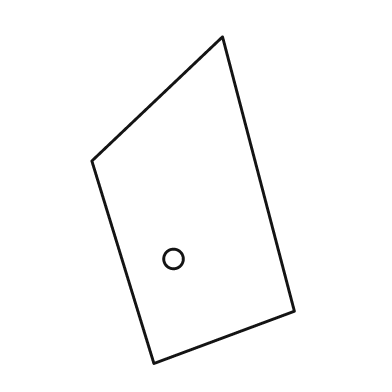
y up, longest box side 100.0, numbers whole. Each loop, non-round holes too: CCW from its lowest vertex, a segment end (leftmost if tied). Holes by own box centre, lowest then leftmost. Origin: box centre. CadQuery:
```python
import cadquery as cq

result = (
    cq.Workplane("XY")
    .moveTo(-12.0, -50.0)
    .lineTo(31.0, -34.0)
    .lineTo(9.0, 50.0)
    .lineTo(-31.0, 12.0)
    .close()
    .moveTo(-6.0, -18.0)
    .circle(3.0)
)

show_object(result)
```